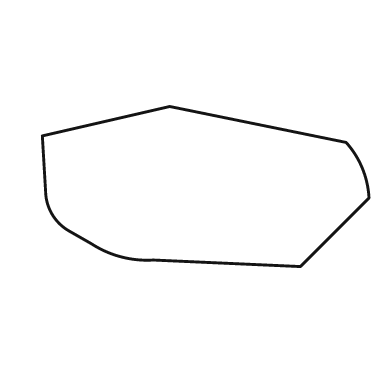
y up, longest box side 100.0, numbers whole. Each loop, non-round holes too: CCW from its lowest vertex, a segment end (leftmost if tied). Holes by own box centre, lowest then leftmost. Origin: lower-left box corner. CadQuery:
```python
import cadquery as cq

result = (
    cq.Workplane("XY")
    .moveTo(79.0, 0.0)
    .lineTo(100.0, 21.0)
    .threePointArc((98.0, 30.0), (93.0, 38.0))
    .lineTo(39.0, 49.0)
    .lineTo(0.0, 40.0)
    .lineTo(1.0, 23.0)
    .threePointArc((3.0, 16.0), (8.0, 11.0))
    .lineTo(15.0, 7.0)
    .threePointArc((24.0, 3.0), (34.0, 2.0))
    .close()
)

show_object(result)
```